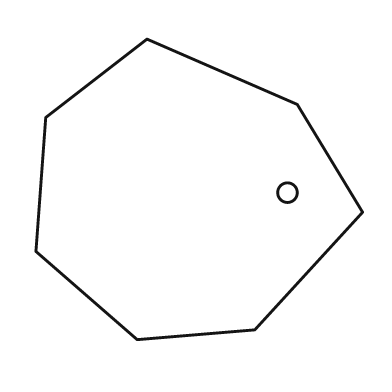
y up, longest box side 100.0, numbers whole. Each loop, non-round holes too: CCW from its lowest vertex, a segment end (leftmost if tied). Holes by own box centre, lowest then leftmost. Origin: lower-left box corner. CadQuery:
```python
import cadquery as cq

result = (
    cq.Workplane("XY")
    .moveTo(31.0, 0.0)
    .lineTo(67.0, 3.0)
    .lineTo(100.0, 39.0)
    .lineTo(80.0, 72.0)
    .lineTo(34.0, 92.0)
    .lineTo(3.0, 68.0)
    .lineTo(0.0, 27.0)
    .close()
    .moveTo(77.0, 45.0)
    .circle(3.0)
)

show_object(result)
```